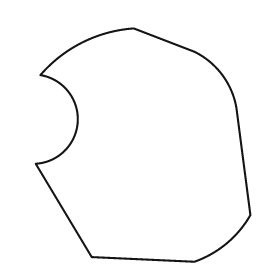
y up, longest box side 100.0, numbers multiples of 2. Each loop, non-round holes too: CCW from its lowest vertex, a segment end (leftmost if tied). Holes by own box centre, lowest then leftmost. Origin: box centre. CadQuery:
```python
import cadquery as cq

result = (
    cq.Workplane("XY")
    .moveTo(22.0, -50.0)
    .threePointArc((36.0, -42.0), (46.0, -30.0))
    .lineTo(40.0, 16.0)
    .threePointArc((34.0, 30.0), (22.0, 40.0))
    .lineTo(-4.0, 50.0)
    .threePointArc((-26.0, 44.0), (-44.0, 30.0))
    .threePointArc((-28.0, 10.0), (-46.0, -8.0))
    .lineTo(-22.0, -48.0)
    .close()
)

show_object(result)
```